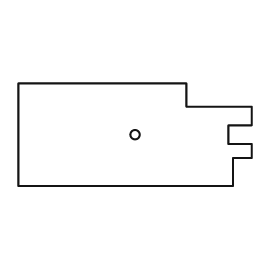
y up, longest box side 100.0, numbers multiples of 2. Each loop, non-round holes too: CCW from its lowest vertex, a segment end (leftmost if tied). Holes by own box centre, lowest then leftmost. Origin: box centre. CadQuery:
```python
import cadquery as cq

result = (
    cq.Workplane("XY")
    .moveTo(-50.0, -22.0)
    .lineTo(42.0, -22.0)
    .lineTo(42.0, -10.0)
    .lineTo(50.0, -10.0)
    .lineTo(50.0, -4.0)
    .lineTo(40.0, -4.0)
    .lineTo(40.0, 4.0)
    .lineTo(50.0, 4.0)
    .lineTo(50.0, 12.0)
    .lineTo(22.0, 12.0)
    .lineTo(22.0, 22.0)
    .lineTo(-50.0, 22.0)
    .close()
    .moveTo(0.0, 0.0)
    .circle(2.0)
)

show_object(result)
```